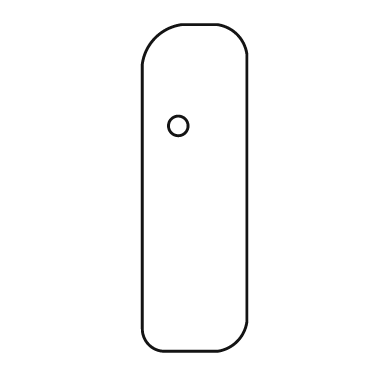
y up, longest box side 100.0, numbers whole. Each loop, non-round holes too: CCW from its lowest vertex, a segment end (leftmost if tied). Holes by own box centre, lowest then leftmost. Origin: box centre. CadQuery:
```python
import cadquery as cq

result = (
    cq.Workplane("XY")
    .moveTo(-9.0, -50.0)
    .lineTo(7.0, -50.0)
    .threePointArc((13.0, -47.0), (16.0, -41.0))
    .lineTo(16.0, 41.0)
    .threePointArc((13.0, 47.0), (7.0, 50.0))
    .lineTo(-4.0, 50.0)
    .threePointArc((-12.0, 46.0), (-16.0, 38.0))
    .lineTo(-16.0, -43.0)
    .threePointArc((-14.0, -48.0), (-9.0, -50.0))
    .close()
    .moveTo(-5.0, 19.0)
    .circle(3.0)
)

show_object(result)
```